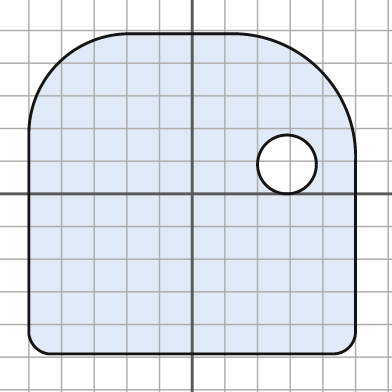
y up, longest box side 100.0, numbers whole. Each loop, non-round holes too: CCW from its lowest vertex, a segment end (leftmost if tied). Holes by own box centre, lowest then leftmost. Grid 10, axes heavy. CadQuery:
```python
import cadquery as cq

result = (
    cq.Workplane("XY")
    .moveTo(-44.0, -49.0)
    .lineTo(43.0, -49.0)
    .threePointArc((48.0, -47.0), (50.0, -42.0))
    .lineTo(50.0, 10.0)
    .threePointArc((39.0, 38.0), (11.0, 49.0))
    .lineTo(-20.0, 49.0)
    .threePointArc((-41.0, 40.0), (-50.0, 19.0))
    .lineTo(-50.0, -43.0)
    .threePointArc((-48.0, -47.0), (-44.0, -49.0))
    .close()
    .moveTo(29.0, 9.0)
    .circle(9.0)
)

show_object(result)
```